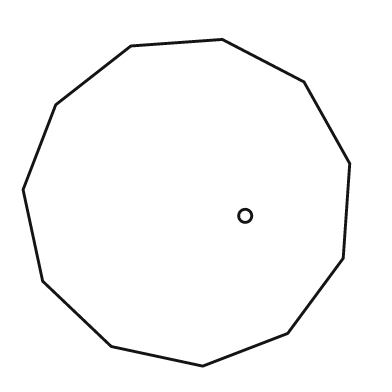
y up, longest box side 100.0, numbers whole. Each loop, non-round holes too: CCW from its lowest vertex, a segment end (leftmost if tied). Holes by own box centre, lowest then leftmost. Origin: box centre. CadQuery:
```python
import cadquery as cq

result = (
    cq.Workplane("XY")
    .moveTo(5.0, -50.0)
    .lineTo(31.0, -40.0)
    .lineTo(48.0, -17.0)
    .lineTo(50.0, 12.0)
    .lineTo(36.0, 37.0)
    .lineTo(11.0, 50.0)
    .lineTo(-17.0, 48.0)
    .lineTo(-40.0, 30.0)
    .lineTo(-50.0, 4.0)
    .lineTo(-44.0, -24.0)
    .lineTo(-23.0, -44.0)
    .close()
    .moveTo(18.0, -4.0)
    .circle(2.0)
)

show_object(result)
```